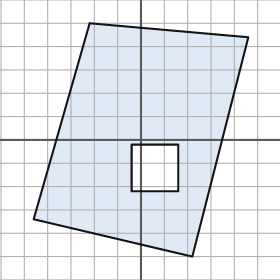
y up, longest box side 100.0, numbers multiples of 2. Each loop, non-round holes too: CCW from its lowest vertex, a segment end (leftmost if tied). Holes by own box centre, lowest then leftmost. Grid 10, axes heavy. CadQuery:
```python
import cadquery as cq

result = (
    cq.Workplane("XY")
    .moveTo(22.0, -50.0)
    .lineTo(46.0, 44.0)
    .lineTo(-22.0, 50.0)
    .lineTo(-46.0, -34.0)
    .close()
    .moveTo(-4.0, -22.0)
    .lineTo(16.0, -22.0)
    .lineTo(16.0, -2.0)
    .lineTo(-4.0, -2.0)
    .close()
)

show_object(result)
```